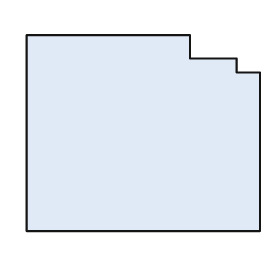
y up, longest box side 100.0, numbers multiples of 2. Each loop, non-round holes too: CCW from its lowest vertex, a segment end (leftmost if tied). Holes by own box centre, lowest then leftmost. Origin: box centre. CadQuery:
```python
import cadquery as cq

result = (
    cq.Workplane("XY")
    .moveTo(-50.0, -42.0)
    .lineTo(50.0, -42.0)
    .lineTo(50.0, 26.0)
    .lineTo(40.0, 26.0)
    .lineTo(40.0, 32.0)
    .lineTo(20.0, 32.0)
    .lineTo(20.0, 42.0)
    .lineTo(-50.0, 42.0)
    .close()
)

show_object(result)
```